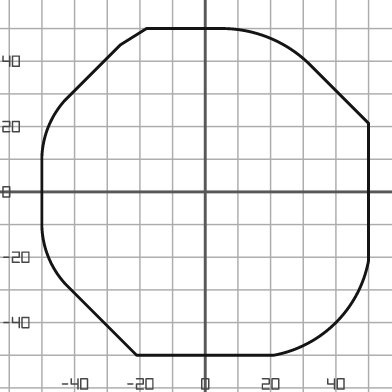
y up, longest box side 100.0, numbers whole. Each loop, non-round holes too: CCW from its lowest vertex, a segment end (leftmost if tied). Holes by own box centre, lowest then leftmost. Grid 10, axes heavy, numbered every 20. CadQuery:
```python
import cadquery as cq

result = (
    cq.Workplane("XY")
    .moveTo(-21.0, -50.0)
    .lineTo(21.0, -50.0)
    .threePointArc((40.0, -40.0), (50.0, -21.0))
    .lineTo(50.0, 21.0)
    .lineTo(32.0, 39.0)
    .threePointArc((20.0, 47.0), (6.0, 50.0))
    .lineTo(-18.0, 50.0)
    .lineTo(-26.0, 45.0)
    .lineTo(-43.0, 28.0)
    .threePointArc((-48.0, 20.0), (-50.0, 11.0))
    .lineTo(-50.0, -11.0)
    .threePointArc((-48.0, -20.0), (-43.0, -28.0))
    .close()
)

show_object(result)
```